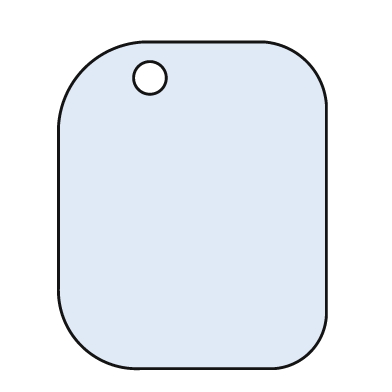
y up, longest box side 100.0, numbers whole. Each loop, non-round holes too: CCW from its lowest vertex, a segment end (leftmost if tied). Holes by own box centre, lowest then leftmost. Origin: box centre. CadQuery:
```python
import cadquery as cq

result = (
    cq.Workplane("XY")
    .moveTo(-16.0, -50.0)
    .lineTo(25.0, -50.0)
    .threePointArc((36.0, -45.0), (41.0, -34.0))
    .lineTo(41.0, 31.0)
    .threePointArc((35.0, 44.0), (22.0, 50.0))
    .lineTo(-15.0, 50.0)
    .threePointArc((-33.0, 42.0), (-41.0, 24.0))
    .lineTo(-41.0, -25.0)
    .threePointArc((-34.0, -43.0), (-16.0, -50.0))
    .close()
    .moveTo(-13.0, 39.0)
    .circle(5.0)
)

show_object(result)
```